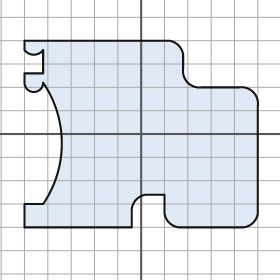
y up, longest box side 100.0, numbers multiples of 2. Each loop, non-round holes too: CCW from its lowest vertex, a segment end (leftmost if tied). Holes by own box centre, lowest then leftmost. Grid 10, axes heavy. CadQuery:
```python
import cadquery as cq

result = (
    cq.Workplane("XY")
    .moveTo(-50.0, -40.0)
    .lineTo(-4.0, -40.0)
    .lineTo(-4.0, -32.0)
    .threePointArc((-2.0, -28.0), (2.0, -26.0))
    .lineTo(10.0, -26.0)
    .lineTo(10.0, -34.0)
    .threePointArc((12.0, -38.0), (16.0, -40.0))
    .lineTo(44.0, -40.0)
    .threePointArc((48.0, -38.0), (50.0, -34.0))
    .lineTo(50.0, 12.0)
    .threePointArc((48.0, 18.0), (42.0, 20.0))
    .lineTo(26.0, 20.0)
    .threePointArc((20.0, 22.0), (18.0, 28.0))
    .lineTo(18.0, 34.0)
    .threePointArc((16.0, 38.0), (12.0, 40.0))
    .lineTo(-50.0, 40.0)
    .lineTo(-50.0, 36.0)
    .threePointArc((-46.0, 34.0), (-42.0, 36.0))
    .lineTo(-42.0, 26.0)
    .lineTo(-50.0, 26.0)
    .lineTo(-50.0, 22.0)
    .threePointArc((-46.0, 18.0), (-42.0, 22.0))
    .threePointArc((-34.0, -4.0), (-42.0, -30.0))
    .lineTo(-50.0, -30.0)
    .close()
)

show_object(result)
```